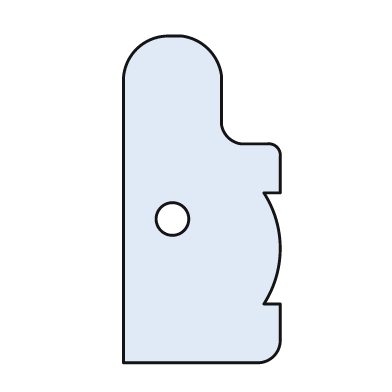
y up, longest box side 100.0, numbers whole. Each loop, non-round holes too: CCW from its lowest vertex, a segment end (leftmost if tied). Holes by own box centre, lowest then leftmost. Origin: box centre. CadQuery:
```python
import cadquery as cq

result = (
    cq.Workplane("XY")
    .moveTo(-24.0, -50.0)
    .lineTo(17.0, -50.0)
    .threePointArc((22.0, -48.0), (24.0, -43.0))
    .lineTo(24.0, -32.0)
    .lineTo(19.0, -32.0)
    .threePointArc((24.0, -15.0), (19.0, 2.0))
    .lineTo(24.0, 2.0)
    .lineTo(24.0, 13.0)
    .threePointArc((23.0, 16.0), (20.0, 17.0))
    .lineTo(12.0, 17.0)
    .threePointArc((8.0, 19.0), (6.0, 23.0))
    .lineTo(6.0, 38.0)
    .threePointArc((2.0, 46.0), (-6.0, 50.0))
    .lineTo(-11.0, 50.0)
    .threePointArc((-20.0, 46.0), (-24.0, 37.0))
    .close()
    .moveTo(-9.0, -6.0)
    .circle(5.0)
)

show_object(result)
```